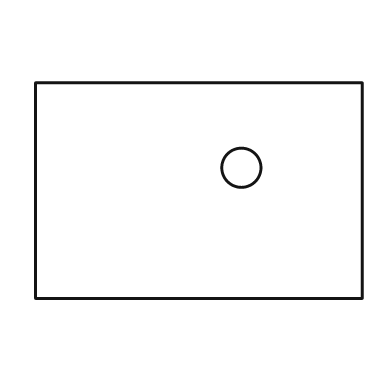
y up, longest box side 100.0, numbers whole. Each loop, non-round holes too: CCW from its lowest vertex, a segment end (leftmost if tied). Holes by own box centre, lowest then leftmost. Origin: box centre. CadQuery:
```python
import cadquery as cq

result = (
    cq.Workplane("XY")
    .moveTo(-50.0, -33.0)
    .lineTo(50.0, -33.0)
    .lineTo(50.0, 33.0)
    .lineTo(-50.0, 33.0)
    .close()
    .moveTo(13.0, 7.0)
    .circle(6.0)
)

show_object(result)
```